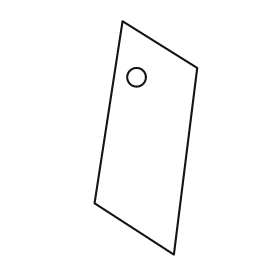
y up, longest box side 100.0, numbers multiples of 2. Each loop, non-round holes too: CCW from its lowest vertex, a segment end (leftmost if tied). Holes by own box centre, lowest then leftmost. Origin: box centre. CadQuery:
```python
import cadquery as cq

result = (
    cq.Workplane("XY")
    .moveTo(12.0, -50.0)
    .lineTo(22.0, 30.0)
    .lineTo(-10.0, 50.0)
    .lineTo(-22.0, -28.0)
    .close()
    .moveTo(-4.0, 26.0)
    .circle(4.0)
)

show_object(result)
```